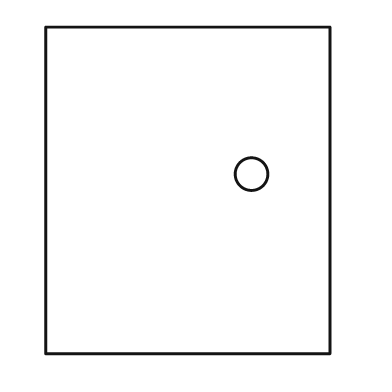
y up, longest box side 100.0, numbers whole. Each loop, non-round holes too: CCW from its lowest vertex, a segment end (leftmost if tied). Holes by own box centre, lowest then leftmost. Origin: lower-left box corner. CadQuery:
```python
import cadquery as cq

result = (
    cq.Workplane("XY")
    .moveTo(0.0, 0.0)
    .lineTo(87.0, 0.0)
    .lineTo(87.0, 100.0)
    .lineTo(0.0, 100.0)
    .close()
    .moveTo(63.0, 55.0)
    .circle(5.0)
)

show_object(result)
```